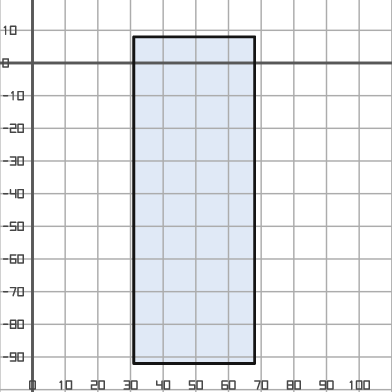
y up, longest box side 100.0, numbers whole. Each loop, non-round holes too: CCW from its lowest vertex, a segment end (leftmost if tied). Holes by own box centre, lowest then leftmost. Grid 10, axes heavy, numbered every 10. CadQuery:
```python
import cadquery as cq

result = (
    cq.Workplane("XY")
    .moveTo(31.0, -92.0)
    .lineTo(68.0, -92.0)
    .lineTo(68.0, 8.0)
    .lineTo(31.0, 8.0)
    .close()
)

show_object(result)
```